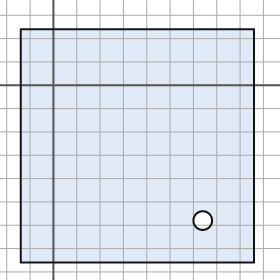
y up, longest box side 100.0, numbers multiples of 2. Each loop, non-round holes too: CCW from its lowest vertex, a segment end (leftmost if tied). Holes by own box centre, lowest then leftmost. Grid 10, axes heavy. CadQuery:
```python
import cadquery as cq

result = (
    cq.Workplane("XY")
    .moveTo(-14.0, -76.0)
    .lineTo(86.0, -76.0)
    .lineTo(86.0, 24.0)
    .lineTo(-14.0, 24.0)
    .close()
    .moveTo(64.0, -58.0)
    .circle(4.0)
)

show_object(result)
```